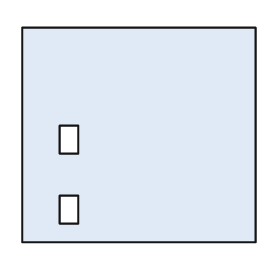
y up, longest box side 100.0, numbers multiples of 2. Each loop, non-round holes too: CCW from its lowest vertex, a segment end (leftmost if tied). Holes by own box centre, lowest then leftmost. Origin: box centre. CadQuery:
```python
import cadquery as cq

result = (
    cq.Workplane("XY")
    .moveTo(-50.0, -46.0)
    .lineTo(50.0, -46.0)
    .lineTo(50.0, 46.0)
    .lineTo(-50.0, 46.0)
    .close()
    .moveTo(-34.0, -38.0)
    .lineTo(-26.0, -38.0)
    .lineTo(-26.0, -26.0)
    .lineTo(-34.0, -26.0)
    .close()
    .moveTo(-34.0, -8.0)
    .lineTo(-26.0, -8.0)
    .lineTo(-26.0, 4.0)
    .lineTo(-34.0, 4.0)
    .close()
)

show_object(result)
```